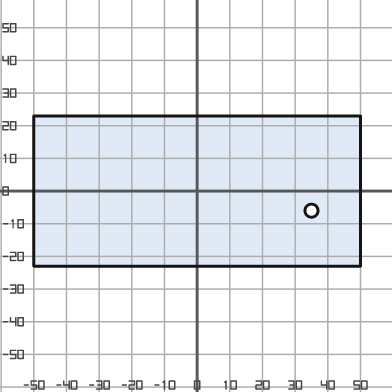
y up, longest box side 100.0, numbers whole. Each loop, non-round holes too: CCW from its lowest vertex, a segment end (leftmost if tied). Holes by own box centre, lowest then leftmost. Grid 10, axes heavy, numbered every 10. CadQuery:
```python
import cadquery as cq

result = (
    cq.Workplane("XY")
    .moveTo(-50.0, -23.0)
    .lineTo(50.0, -23.0)
    .lineTo(50.0, 23.0)
    .lineTo(-50.0, 23.0)
    .close()
    .moveTo(35.0, -6.0)
    .circle(2.0)
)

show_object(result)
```